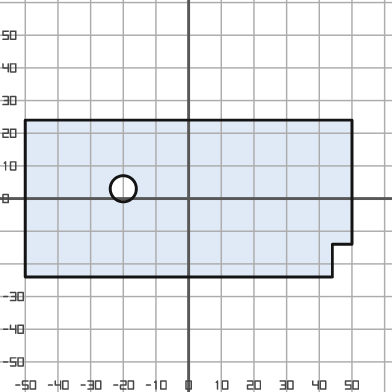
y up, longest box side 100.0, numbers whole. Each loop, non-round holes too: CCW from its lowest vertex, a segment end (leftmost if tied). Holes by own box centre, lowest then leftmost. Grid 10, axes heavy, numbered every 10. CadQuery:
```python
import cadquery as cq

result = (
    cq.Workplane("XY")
    .moveTo(-50.0, -24.0)
    .lineTo(44.0, -24.0)
    .lineTo(44.0, -14.0)
    .lineTo(50.0, -14.0)
    .lineTo(50.0, 24.0)
    .lineTo(-50.0, 24.0)
    .close()
    .moveTo(-20.0, 3.0)
    .circle(4.0)
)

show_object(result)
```